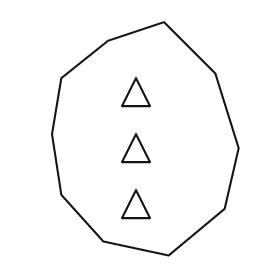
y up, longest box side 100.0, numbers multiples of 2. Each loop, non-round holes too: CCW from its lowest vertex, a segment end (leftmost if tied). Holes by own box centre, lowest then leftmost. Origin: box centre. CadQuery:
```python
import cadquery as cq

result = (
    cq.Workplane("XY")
    .moveTo(10.0, -50.0)
    .lineTo(34.0, -30.0)
    .lineTo(40.0, -4.0)
    .lineTo(30.0, 28.0)
    .lineTo(8.0, 50.0)
    .lineTo(-16.0, 42.0)
    .lineTo(-36.0, 26.0)
    .lineTo(-40.0, 2.0)
    .lineTo(-36.0, -24.0)
    .lineTo(-18.0, -44.0)
    .close()
    .moveTo(-10.0, -34.0)
    .lineTo(2.0, -34.0)
    .lineTo(-4.0, -22.0)
    .close()
    .moveTo(-10.0, -10.0)
    .lineTo(2.0, -10.0)
    .lineTo(-4.0, 2.0)
    .close()
    .moveTo(-10.0, 14.0)
    .lineTo(2.0, 14.0)
    .lineTo(-4.0, 26.0)
    .close()
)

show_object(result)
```